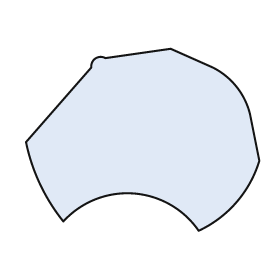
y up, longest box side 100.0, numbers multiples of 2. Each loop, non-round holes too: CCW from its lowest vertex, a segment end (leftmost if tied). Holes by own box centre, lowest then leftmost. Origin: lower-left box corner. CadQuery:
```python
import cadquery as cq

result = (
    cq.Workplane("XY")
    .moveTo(74.0, 0.0)
    .threePointArc((90.0, 12.0), (100.0, 30.0))
    .lineTo(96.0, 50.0)
    .threePointArc((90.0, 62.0), (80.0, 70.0))
    .lineTo(62.0, 78.0)
    .lineTo(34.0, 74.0)
    .threePointArc((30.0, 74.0), (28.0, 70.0))
    .lineTo(0.0, 38.0)
    .threePointArc((6.0, 20.0), (16.0, 4.0))
    .threePointArc((46.0, 16.0), (74.0, 0.0))
    .close()
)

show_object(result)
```